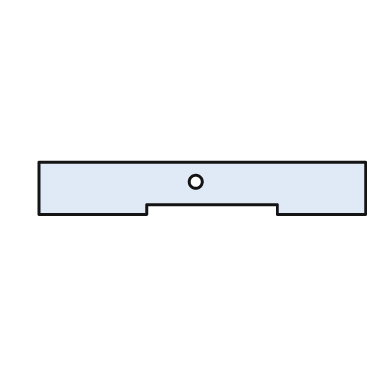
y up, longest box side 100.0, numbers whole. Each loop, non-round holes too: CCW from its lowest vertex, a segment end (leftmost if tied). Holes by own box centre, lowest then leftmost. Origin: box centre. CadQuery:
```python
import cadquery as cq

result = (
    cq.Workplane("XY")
    .moveTo(-50.0, -8.0)
    .lineTo(-17.0, -8.0)
    .lineTo(-17.0, -5.0)
    .lineTo(23.0, -5.0)
    .lineTo(23.0, -8.0)
    .lineTo(50.0, -8.0)
    .lineTo(50.0, 8.0)
    .lineTo(-50.0, 8.0)
    .close()
    .moveTo(-2.0, 2.0)
    .circle(2.0)
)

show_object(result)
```